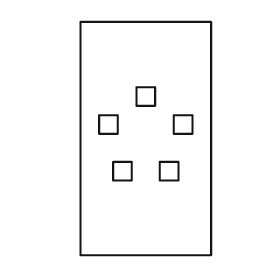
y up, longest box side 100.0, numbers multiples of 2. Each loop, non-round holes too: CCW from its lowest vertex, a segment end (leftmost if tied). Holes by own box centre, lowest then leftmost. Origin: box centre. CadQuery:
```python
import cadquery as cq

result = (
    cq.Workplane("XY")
    .moveTo(-28.0, -50.0)
    .lineTo(28.0, -50.0)
    .lineTo(28.0, 50.0)
    .lineTo(-28.0, 50.0)
    .close()
    .moveTo(-14.0, -18.0)
    .lineTo(-6.0, -18.0)
    .lineTo(-6.0, -10.0)
    .lineTo(-14.0, -10.0)
    .close()
    .moveTo(6.0, -18.0)
    .lineTo(14.0, -18.0)
    .lineTo(14.0, -10.0)
    .lineTo(6.0, -10.0)
    .close()
    .moveTo(-20.0, 2.0)
    .lineTo(-12.0, 2.0)
    .lineTo(-12.0, 10.0)
    .lineTo(-20.0, 10.0)
    .close()
    .moveTo(12.0, 2.0)
    .lineTo(20.0, 2.0)
    .lineTo(20.0, 10.0)
    .lineTo(12.0, 10.0)
    .close()
    .moveTo(-4.0, 14.0)
    .lineTo(4.0, 14.0)
    .lineTo(4.0, 22.0)
    .lineTo(-4.0, 22.0)
    .close()
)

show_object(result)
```